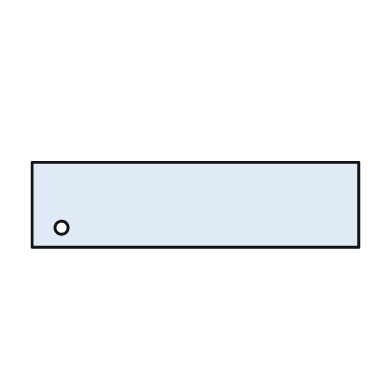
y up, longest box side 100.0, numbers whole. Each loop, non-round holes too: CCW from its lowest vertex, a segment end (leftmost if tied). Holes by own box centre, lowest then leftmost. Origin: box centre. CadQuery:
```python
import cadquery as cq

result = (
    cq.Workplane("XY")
    .moveTo(-50.0, -13.0)
    .lineTo(50.0, -13.0)
    .lineTo(50.0, 13.0)
    .lineTo(-50.0, 13.0)
    .close()
    .moveTo(-41.0, -7.0)
    .circle(2.0)
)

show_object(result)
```